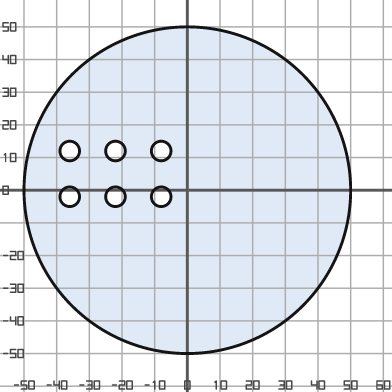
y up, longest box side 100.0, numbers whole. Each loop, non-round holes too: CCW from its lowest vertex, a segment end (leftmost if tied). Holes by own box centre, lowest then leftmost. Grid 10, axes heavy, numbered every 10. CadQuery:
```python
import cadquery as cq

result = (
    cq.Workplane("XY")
    .moveTo(0.0, 0.0)
    .circle(50.0)
    .moveTo(-36.0, -2.0)
    .circle(3.0)
    .moveTo(-22.0, -2.0)
    .circle(3.0)
    .moveTo(-8.0, -2.0)
    .circle(3.0)
    .moveTo(-36.0, 12.0)
    .circle(3.0)
    .moveTo(-22.0, 12.0)
    .circle(3.0)
    .moveTo(-8.0, 12.0)
    .circle(3.0)
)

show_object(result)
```